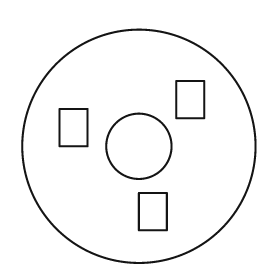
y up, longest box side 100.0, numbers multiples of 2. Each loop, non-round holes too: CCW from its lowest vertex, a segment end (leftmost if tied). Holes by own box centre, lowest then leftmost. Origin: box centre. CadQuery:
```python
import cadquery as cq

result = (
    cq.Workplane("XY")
    .moveTo(0.0, 0.0)
    .circle(50.0)
    .moveTo(0.0, -36.0)
    .lineTo(12.0, -36.0)
    .lineTo(12.0, -20.0)
    .lineTo(0.0, -20.0)
    .close()
    .moveTo(0.0, 0.0)
    .circle(14.0)
    .moveTo(-34.0, 0.0)
    .lineTo(-22.0, 0.0)
    .lineTo(-22.0, 16.0)
    .lineTo(-34.0, 16.0)
    .close()
    .moveTo(16.0, 12.0)
    .lineTo(28.0, 12.0)
    .lineTo(28.0, 28.0)
    .lineTo(16.0, 28.0)
    .close()
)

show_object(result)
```